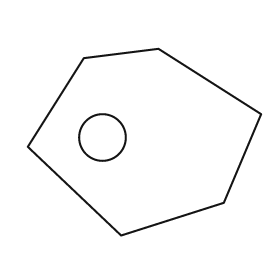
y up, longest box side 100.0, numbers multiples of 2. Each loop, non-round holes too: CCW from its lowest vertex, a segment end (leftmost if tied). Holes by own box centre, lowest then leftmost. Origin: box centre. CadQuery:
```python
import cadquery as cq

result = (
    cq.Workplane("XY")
    .moveTo(-10.0, -40.0)
    .lineTo(34.0, -26.0)
    .lineTo(50.0, 12.0)
    .lineTo(6.0, 40.0)
    .lineTo(-26.0, 36.0)
    .lineTo(-50.0, -2.0)
    .close()
    .moveTo(-18.0, 2.0)
    .circle(10.0)
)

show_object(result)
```